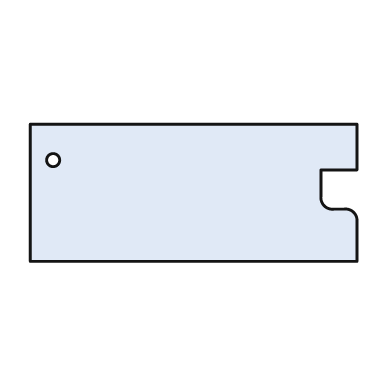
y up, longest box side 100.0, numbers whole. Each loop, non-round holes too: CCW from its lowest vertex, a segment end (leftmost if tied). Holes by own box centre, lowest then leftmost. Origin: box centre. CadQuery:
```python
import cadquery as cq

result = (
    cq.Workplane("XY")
    .moveTo(-50.0, -21.0)
    .lineTo(50.0, -21.0)
    .lineTo(50.0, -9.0)
    .threePointArc((49.0, -6.0), (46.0, -5.0))
    .lineTo(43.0, -5.0)
    .threePointArc((40.0, -4.0), (39.0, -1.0))
    .lineTo(39.0, 7.0)
    .lineTo(50.0, 7.0)
    .lineTo(50.0, 21.0)
    .lineTo(-50.0, 21.0)
    .close()
    .moveTo(-43.0, 10.0)
    .circle(2.0)
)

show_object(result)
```